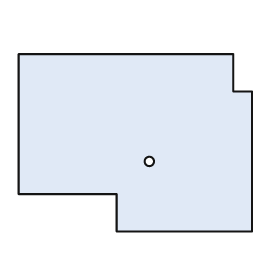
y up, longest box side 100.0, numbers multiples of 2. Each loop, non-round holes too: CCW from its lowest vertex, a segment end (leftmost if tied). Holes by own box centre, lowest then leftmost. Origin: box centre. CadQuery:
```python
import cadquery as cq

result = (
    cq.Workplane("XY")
    .moveTo(-8.0, -38.0)
    .lineTo(50.0, -38.0)
    .lineTo(50.0, 22.0)
    .lineTo(42.0, 22.0)
    .lineTo(42.0, 38.0)
    .lineTo(-50.0, 38.0)
    .lineTo(-50.0, -22.0)
    .lineTo(-8.0, -22.0)
    .close()
    .moveTo(6.0, -8.0)
    .circle(2.0)
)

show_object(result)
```